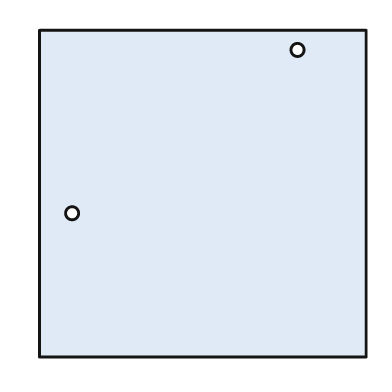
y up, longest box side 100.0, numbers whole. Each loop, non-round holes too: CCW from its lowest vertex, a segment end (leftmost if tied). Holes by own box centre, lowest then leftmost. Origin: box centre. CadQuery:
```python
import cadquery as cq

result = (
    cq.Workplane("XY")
    .moveTo(-50.0, -50.0)
    .lineTo(50.0, -50.0)
    .lineTo(50.0, 50.0)
    .lineTo(-50.0, 50.0)
    .close()
    .moveTo(-40.0, -6.0)
    .circle(2.0)
    .moveTo(29.0, 44.0)
    .circle(2.0)
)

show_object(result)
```